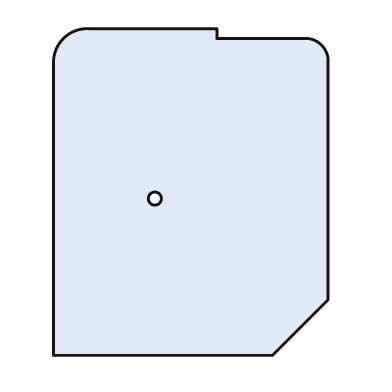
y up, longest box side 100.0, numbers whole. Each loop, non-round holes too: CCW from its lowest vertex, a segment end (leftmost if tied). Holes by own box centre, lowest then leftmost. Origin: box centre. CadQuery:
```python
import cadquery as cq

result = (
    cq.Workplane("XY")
    .moveTo(-42.0, -50.0)
    .lineTo(25.0, -50.0)
    .lineTo(42.0, -33.0)
    .lineTo(42.0, 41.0)
    .threePointArc((40.0, 45.0), (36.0, 47.0))
    .lineTo(8.0, 47.0)
    .lineTo(8.0, 50.0)
    .lineTo(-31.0, 50.0)
    .threePointArc((-39.0, 47.0), (-42.0, 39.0))
    .close()
    .moveTo(-11.0, -2.0)
    .circle(2.0)
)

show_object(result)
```